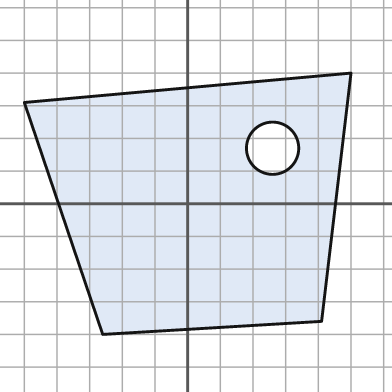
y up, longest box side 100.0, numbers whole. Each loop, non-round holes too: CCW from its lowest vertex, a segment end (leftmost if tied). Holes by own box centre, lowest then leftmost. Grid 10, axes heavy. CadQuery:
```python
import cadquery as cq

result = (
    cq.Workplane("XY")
    .moveTo(-26.0, -40.0)
    .lineTo(41.0, -36.0)
    .lineTo(50.0, 40.0)
    .lineTo(-50.0, 31.0)
    .close()
    .moveTo(26.0, 17.0)
    .circle(8.0)
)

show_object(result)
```